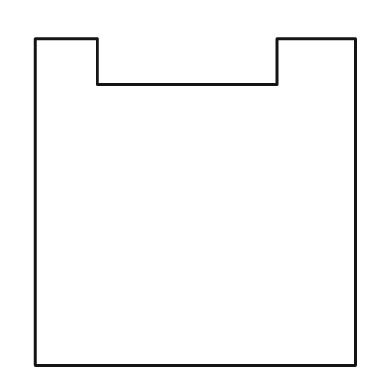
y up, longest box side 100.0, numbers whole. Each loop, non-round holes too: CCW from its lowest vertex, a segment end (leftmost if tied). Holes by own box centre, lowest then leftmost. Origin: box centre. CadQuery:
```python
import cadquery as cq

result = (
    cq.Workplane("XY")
    .moveTo(-49.0, -50.0)
    .lineTo(49.0, -50.0)
    .lineTo(49.0, 50.0)
    .lineTo(25.0, 50.0)
    .lineTo(25.0, 36.0)
    .lineTo(-30.0, 36.0)
    .lineTo(-30.0, 50.0)
    .lineTo(-49.0, 50.0)
    .close()
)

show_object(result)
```